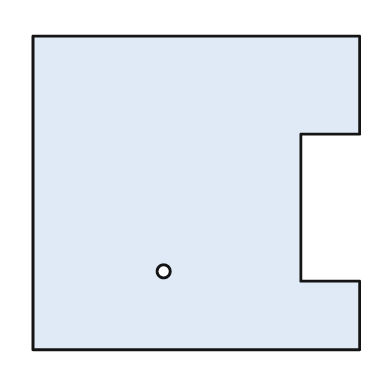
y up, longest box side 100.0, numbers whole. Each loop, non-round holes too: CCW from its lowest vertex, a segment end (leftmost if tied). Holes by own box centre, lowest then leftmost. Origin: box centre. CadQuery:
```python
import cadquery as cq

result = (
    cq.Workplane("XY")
    .moveTo(-50.0, -48.0)
    .lineTo(50.0, -48.0)
    .lineTo(50.0, -27.0)
    .lineTo(32.0, -27.0)
    .lineTo(32.0, 18.0)
    .lineTo(50.0, 18.0)
    .lineTo(50.0, 48.0)
    .lineTo(-50.0, 48.0)
    .close()
    .moveTo(-10.0, -24.0)
    .circle(2.0)
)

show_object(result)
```